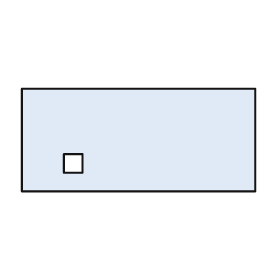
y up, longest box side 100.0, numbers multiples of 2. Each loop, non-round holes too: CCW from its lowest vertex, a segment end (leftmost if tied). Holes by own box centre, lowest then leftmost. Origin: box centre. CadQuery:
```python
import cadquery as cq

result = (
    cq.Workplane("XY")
    .moveTo(-50.0, -22.0)
    .lineTo(50.0, -22.0)
    .lineTo(50.0, 22.0)
    .lineTo(-50.0, 22.0)
    .close()
    .moveTo(-32.0, -14.0)
    .lineTo(-24.0, -14.0)
    .lineTo(-24.0, -6.0)
    .lineTo(-32.0, -6.0)
    .close()
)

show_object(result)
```